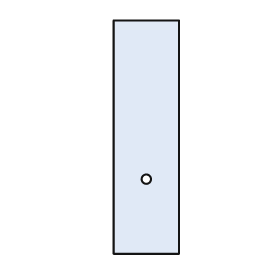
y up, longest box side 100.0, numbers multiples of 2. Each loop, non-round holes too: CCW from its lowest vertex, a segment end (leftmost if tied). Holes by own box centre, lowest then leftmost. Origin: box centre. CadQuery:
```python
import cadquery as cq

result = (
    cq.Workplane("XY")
    .moveTo(-14.0, -50.0)
    .lineTo(14.0, -50.0)
    .lineTo(14.0, 50.0)
    .lineTo(-14.0, 50.0)
    .close()
    .moveTo(0.0, -18.0)
    .circle(2.0)
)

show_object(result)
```